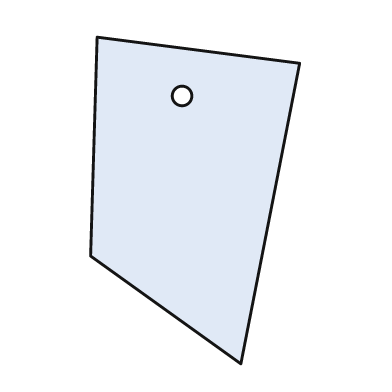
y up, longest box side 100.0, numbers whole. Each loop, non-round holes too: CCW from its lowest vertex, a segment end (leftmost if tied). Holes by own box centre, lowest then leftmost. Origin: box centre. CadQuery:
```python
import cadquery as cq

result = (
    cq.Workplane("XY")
    .moveTo(14.0, -50.0)
    .lineTo(32.0, 42.0)
    .lineTo(-30.0, 50.0)
    .lineTo(-32.0, -17.0)
    .close()
    .moveTo(-4.0, 32.0)
    .circle(3.0)
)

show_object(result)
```